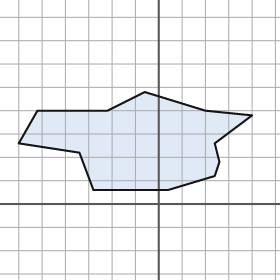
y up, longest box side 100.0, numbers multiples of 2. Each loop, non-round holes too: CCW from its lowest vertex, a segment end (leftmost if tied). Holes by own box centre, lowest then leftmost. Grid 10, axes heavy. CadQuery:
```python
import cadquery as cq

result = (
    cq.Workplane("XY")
    .moveTo(-28.0, 6.0)
    .lineTo(4.0, 6.0)
    .lineTo(24.0, 12.0)
    .lineTo(26.0, 18.0)
    .lineTo(24.0, 26.0)
    .lineTo(40.0, 38.0)
    .lineTo(20.0, 40.0)
    .lineTo(-6.0, 48.0)
    .lineTo(-22.0, 40.0)
    .lineTo(-52.0, 40.0)
    .lineTo(-60.0, 26.0)
    .lineTo(-34.0, 22.0)
    .close()
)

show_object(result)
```